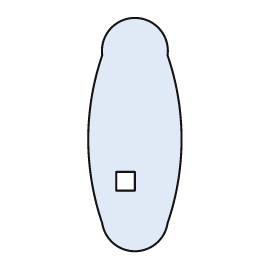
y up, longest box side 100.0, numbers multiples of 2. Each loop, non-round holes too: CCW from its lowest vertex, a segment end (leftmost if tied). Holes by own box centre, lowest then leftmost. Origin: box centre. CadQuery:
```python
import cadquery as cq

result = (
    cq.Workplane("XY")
    .moveTo(-14.0, -38.0)
    .threePointArc((0.0, -50.0), (14.0, -38.0))
    .threePointArc((20.0, -2.0), (14.0, 34.0))
    .threePointArc((0.0, 50.0), (-14.0, 34.0))
    .threePointArc((-20.0, -2.0), (-14.0, -38.0))
    .close()
    .moveTo(-8.0, -24.0)
    .lineTo(0.0, -24.0)
    .lineTo(0.0, -16.0)
    .lineTo(-8.0, -16.0)
    .close()
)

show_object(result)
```